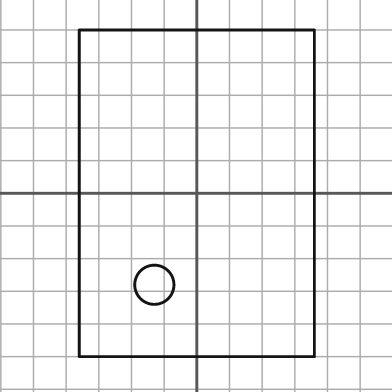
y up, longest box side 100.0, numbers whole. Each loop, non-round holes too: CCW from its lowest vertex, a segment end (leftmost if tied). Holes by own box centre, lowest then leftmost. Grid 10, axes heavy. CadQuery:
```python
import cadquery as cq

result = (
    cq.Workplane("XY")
    .moveTo(-36.0, -50.0)
    .lineTo(36.0, -50.0)
    .lineTo(36.0, 50.0)
    .lineTo(-36.0, 50.0)
    .close()
    .moveTo(-13.0, -28.0)
    .circle(6.0)
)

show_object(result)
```